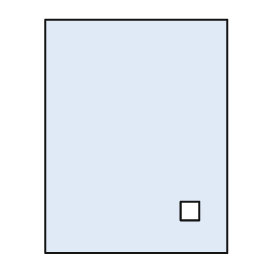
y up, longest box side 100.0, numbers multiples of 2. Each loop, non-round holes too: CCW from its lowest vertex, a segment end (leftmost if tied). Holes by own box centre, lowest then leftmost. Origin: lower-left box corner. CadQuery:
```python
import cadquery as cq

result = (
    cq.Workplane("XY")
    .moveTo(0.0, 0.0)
    .lineTo(78.0, 0.0)
    .lineTo(78.0, 100.0)
    .lineTo(0.0, 100.0)
    .close()
    .moveTo(58.0, 14.0)
    .lineTo(66.0, 14.0)
    .lineTo(66.0, 22.0)
    .lineTo(58.0, 22.0)
    .close()
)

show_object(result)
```